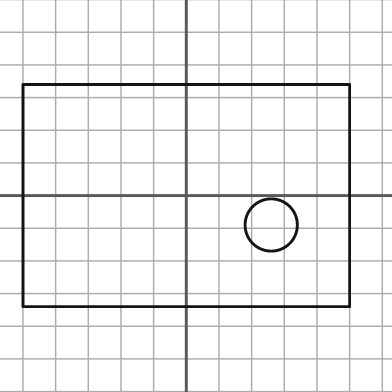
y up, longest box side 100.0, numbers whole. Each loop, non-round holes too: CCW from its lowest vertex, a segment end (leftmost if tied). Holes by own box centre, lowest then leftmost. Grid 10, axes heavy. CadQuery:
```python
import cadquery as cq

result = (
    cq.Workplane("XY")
    .moveTo(-50.0, -34.0)
    .lineTo(50.0, -34.0)
    .lineTo(50.0, 34.0)
    .lineTo(-50.0, 34.0)
    .close()
    .moveTo(26.0, -9.0)
    .circle(8.0)
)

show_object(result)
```